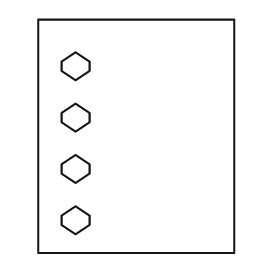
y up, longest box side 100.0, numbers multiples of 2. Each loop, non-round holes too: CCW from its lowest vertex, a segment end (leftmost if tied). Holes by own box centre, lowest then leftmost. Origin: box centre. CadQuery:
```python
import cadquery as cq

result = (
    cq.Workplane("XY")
    .moveTo(-42.0, -50.0)
    .lineTo(42.0, -50.0)
    .lineTo(42.0, 50.0)
    .lineTo(-42.0, 50.0)
    .close()
    .moveTo(-26.0, -42.0)
    .lineTo(-20.0, -38.0)
    .lineTo(-20.0, -34.0)
    .lineTo(-26.0, -30.0)
    .lineTo(-32.0, -34.0)
    .lineTo(-32.0, -38.0)
    .close()
    .moveTo(-26.0, -20.0)
    .lineTo(-20.0, -16.0)
    .lineTo(-20.0, -12.0)
    .lineTo(-26.0, -8.0)
    .lineTo(-32.0, -12.0)
    .lineTo(-32.0, -16.0)
    .close()
    .moveTo(-26.0, 2.0)
    .lineTo(-20.0, 6.0)
    .lineTo(-20.0, 10.0)
    .lineTo(-26.0, 14.0)
    .lineTo(-32.0, 10.0)
    .lineTo(-32.0, 6.0)
    .close()
    .moveTo(-26.0, 24.0)
    .lineTo(-20.0, 28.0)
    .lineTo(-20.0, 32.0)
    .lineTo(-26.0, 36.0)
    .lineTo(-32.0, 32.0)
    .lineTo(-32.0, 28.0)
    .close()
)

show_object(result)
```